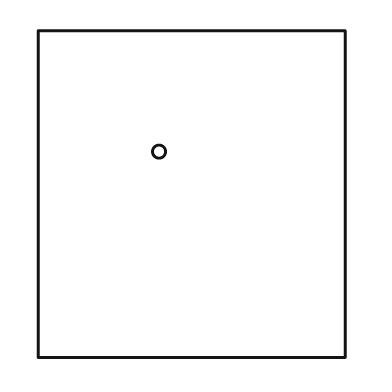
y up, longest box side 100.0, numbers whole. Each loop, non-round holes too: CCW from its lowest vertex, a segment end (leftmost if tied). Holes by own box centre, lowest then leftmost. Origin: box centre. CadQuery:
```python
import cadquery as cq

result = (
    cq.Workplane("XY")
    .moveTo(-47.0, -50.0)
    .lineTo(47.0, -50.0)
    .lineTo(47.0, 50.0)
    .lineTo(-47.0, 50.0)
    .close()
    .moveTo(-10.0, 13.0)
    .circle(2.0)
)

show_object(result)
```